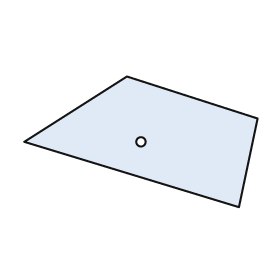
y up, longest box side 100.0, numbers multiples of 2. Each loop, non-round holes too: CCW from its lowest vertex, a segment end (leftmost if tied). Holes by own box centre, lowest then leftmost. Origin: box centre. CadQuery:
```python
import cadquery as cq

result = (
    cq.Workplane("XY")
    .moveTo(42.0, -28.0)
    .lineTo(50.0, 10.0)
    .lineTo(-6.0, 28.0)
    .lineTo(-50.0, 0.0)
    .close()
    .moveTo(0.0, 0.0)
    .circle(2.0)
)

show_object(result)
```